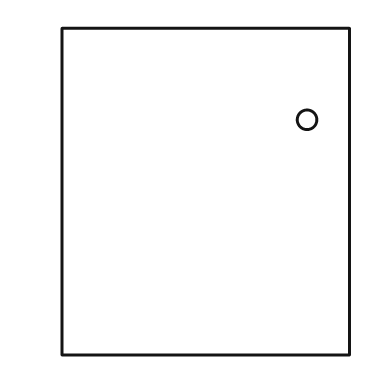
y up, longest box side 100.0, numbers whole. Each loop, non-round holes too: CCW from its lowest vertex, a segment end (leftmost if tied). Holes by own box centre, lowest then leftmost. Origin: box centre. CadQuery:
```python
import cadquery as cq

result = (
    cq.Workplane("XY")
    .moveTo(-44.0, -50.0)
    .lineTo(44.0, -50.0)
    .lineTo(44.0, 50.0)
    .lineTo(-44.0, 50.0)
    .close()
    .moveTo(31.0, 22.0)
    .circle(3.0)
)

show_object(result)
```